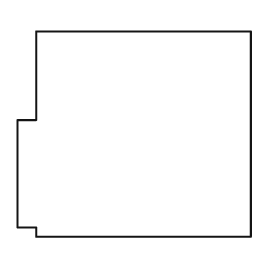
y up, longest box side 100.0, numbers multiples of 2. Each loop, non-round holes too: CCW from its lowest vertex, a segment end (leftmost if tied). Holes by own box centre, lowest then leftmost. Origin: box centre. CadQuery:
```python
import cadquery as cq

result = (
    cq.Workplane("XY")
    .moveTo(-42.0, -44.0)
    .lineTo(50.0, -44.0)
    .lineTo(50.0, 44.0)
    .lineTo(-42.0, 44.0)
    .lineTo(-42.0, 6.0)
    .lineTo(-50.0, 6.0)
    .lineTo(-50.0, -40.0)
    .lineTo(-42.0, -40.0)
    .close()
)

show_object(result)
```